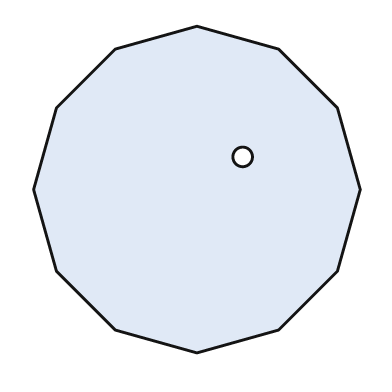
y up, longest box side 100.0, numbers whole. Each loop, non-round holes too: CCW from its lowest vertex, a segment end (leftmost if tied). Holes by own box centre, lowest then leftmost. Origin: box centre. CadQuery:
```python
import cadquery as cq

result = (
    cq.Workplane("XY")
    .moveTo(0.0, -50.0)
    .lineTo(25.0, -43.0)
    .lineTo(43.0, -25.0)
    .lineTo(50.0, 0.0)
    .lineTo(43.0, 25.0)
    .lineTo(25.0, 43.0)
    .lineTo(0.0, 50.0)
    .lineTo(-25.0, 43.0)
    .lineTo(-43.0, 25.0)
    .lineTo(-50.0, 0.0)
    .lineTo(-43.0, -25.0)
    .lineTo(-25.0, -43.0)
    .close()
    .moveTo(14.0, 10.0)
    .circle(3.0)
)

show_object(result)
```